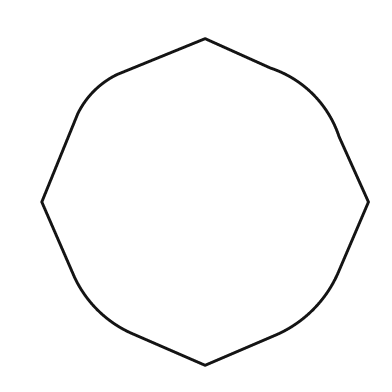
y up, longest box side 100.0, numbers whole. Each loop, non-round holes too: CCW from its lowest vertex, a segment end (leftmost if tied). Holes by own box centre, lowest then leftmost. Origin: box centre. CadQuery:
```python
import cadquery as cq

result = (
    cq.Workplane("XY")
    .moveTo(0.0, -50.0)
    .lineTo(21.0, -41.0)
    .threePointArc((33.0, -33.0), (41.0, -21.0))
    .lineTo(50.0, 0.0)
    .lineTo(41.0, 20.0)
    .threePointArc((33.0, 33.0), (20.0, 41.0))
    .lineTo(0.0, 50.0)
    .lineTo(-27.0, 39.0)
    .threePointArc((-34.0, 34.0), (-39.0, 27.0))
    .lineTo(-50.0, 0.0)
    .lineTo(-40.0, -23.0)
    .threePointArc((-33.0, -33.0), (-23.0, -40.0))
    .close()
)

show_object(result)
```